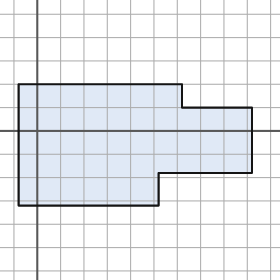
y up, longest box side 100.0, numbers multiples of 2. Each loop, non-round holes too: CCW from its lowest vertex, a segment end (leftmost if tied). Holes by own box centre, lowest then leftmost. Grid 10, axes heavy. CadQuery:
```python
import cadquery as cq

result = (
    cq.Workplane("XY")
    .moveTo(-8.0, -32.0)
    .lineTo(52.0, -32.0)
    .lineTo(52.0, -18.0)
    .lineTo(92.0, -18.0)
    .lineTo(92.0, 10.0)
    .lineTo(62.0, 10.0)
    .lineTo(62.0, 20.0)
    .lineTo(-8.0, 20.0)
    .close()
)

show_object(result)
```